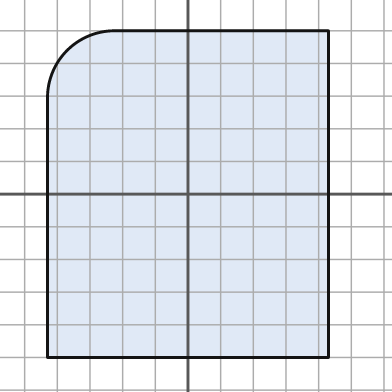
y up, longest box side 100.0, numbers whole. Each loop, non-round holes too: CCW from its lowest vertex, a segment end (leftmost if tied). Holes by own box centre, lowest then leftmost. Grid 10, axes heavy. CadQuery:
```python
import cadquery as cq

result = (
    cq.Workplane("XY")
    .moveTo(-43.0, -50.0)
    .lineTo(43.0, -50.0)
    .lineTo(43.0, 50.0)
    .lineTo(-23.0, 50.0)
    .threePointArc((-37.0, 44.0), (-43.0, 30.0))
    .close()
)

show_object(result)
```